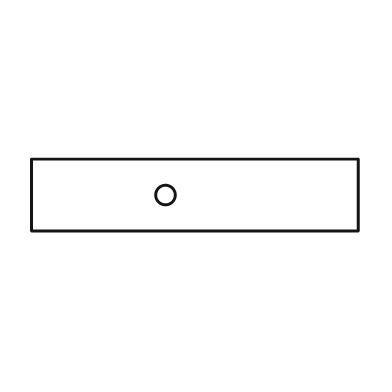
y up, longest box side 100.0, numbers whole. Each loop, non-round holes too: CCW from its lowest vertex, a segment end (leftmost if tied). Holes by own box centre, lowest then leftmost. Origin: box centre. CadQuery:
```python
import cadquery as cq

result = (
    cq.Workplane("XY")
    .moveTo(-50.0, -11.0)
    .lineTo(50.0, -11.0)
    .lineTo(50.0, 11.0)
    .lineTo(-50.0, 11.0)
    .close()
    .moveTo(-9.0, 0.0)
    .circle(3.0)
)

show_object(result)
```